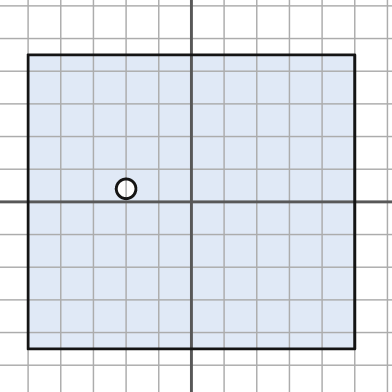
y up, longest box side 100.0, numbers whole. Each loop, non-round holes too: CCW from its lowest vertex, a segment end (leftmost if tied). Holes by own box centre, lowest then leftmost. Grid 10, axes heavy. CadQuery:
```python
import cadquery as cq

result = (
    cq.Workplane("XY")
    .moveTo(-50.0, -45.0)
    .lineTo(50.0, -45.0)
    .lineTo(50.0, 45.0)
    .lineTo(-50.0, 45.0)
    .close()
    .moveTo(-20.0, 4.0)
    .circle(3.0)
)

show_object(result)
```